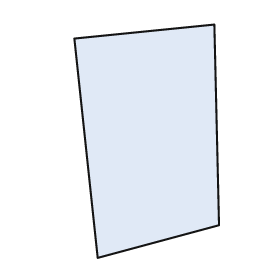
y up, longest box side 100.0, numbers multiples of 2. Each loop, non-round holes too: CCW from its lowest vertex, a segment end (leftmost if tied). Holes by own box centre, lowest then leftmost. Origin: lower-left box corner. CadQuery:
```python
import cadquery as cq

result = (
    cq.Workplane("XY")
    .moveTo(10.0, 0.0)
    .lineTo(62.0, 14.0)
    .lineTo(60.0, 100.0)
    .lineTo(0.0, 94.0)
    .close()
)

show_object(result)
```